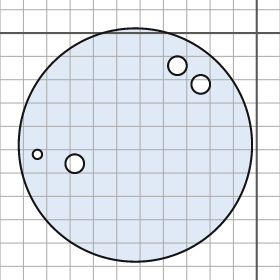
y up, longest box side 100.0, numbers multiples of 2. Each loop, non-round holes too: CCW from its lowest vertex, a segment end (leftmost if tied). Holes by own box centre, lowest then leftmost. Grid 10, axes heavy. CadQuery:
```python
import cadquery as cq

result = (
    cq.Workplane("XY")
    .moveTo(-52.0, -48.0)
    .circle(50.0)
    .moveTo(-78.0, -56.0)
    .circle(4.0)
    .moveTo(-94.0, -52.0)
    .circle(2.0)
    .moveTo(-24.0, -22.0)
    .circle(4.0)
    .moveTo(-34.0, -14.0)
    .circle(4.0)
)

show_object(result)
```